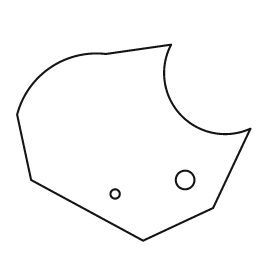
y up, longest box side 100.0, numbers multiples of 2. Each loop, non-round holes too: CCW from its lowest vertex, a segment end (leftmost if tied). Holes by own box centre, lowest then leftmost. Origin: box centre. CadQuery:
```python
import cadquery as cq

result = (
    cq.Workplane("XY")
    .moveTo(4.0, -42.0)
    .lineTo(34.0, -28.0)
    .lineTo(50.0, 6.0)
    .threePointArc((20.0, 12.0), (16.0, 42.0))
    .lineTo(-12.0, 38.0)
    .threePointArc((-36.0, 32.0), (-50.0, 12.0))
    .lineTo(-44.0, -16.0)
    .close()
    .moveTo(-8.0, -22.0)
    .circle(2.0)
    .moveTo(22.0, -16.0)
    .circle(4.0)
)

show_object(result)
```